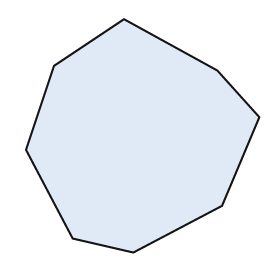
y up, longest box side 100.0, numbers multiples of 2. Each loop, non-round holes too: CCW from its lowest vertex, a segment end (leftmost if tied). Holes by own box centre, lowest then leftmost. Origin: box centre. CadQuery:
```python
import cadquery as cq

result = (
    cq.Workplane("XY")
    .moveTo(-4.0, -50.0)
    .lineTo(34.0, -30.0)
    .lineTo(50.0, 8.0)
    .lineTo(32.0, 28.0)
    .lineTo(-8.0, 50.0)
    .lineTo(-38.0, 30.0)
    .lineTo(-50.0, -6.0)
    .lineTo(-30.0, -44.0)
    .close()
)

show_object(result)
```